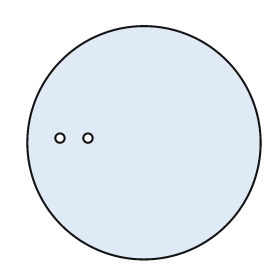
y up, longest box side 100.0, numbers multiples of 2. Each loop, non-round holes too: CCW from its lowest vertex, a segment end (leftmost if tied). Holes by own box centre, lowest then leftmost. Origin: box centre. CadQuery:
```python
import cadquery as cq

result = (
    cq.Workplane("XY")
    .moveTo(0.0, 0.0)
    .circle(50.0)
    .moveTo(-36.0, 2.0)
    .circle(2.0)
    .moveTo(-24.0, 2.0)
    .circle(2.0)
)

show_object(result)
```